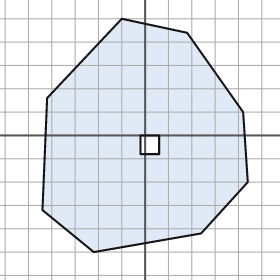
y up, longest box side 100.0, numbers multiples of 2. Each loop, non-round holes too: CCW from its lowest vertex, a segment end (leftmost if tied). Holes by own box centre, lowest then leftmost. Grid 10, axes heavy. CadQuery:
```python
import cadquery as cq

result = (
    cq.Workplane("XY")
    .moveTo(-22.0, -50.0)
    .lineTo(24.0, -42.0)
    .lineTo(44.0, -20.0)
    .lineTo(42.0, 10.0)
    .lineTo(18.0, 44.0)
    .lineTo(-10.0, 50.0)
    .lineTo(-42.0, 16.0)
    .lineTo(-44.0, -32.0)
    .close()
    .moveTo(-2.0, -8.0)
    .lineTo(6.0, -8.0)
    .lineTo(6.0, 0.0)
    .lineTo(-2.0, 0.0)
    .close()
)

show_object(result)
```